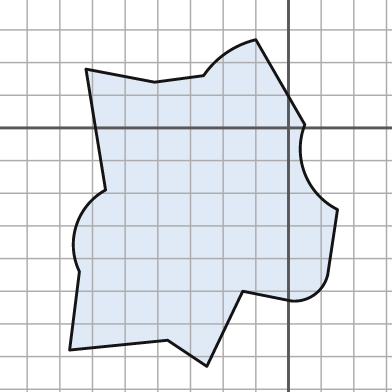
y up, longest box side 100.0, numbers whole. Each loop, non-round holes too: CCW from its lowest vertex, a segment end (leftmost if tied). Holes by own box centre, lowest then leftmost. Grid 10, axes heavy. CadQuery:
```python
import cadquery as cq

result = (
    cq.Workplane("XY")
    .moveTo(-25.0, -73.0)
    .lineTo(-14.0, -50.0)
    .lineTo(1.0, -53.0)
    .threePointArc((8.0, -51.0), (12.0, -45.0))
    .lineTo(15.0, -25.0)
    .threePointArc((5.0, -14.0), (5.0, 1.0))
    .lineTo(-10.0, 27.0)
    .threePointArc((-19.0, 23.0), (-26.0, 16.0))
    .lineTo(-41.0, 14.0)
    .lineTo(-62.0, 18.0)
    .lineTo(-56.0, -19.0)
    .threePointArc((-65.0, -30.0), (-64.0, -44.0))
    .lineTo(-67.0, -68.0)
    .lineTo(-37.0, -65.0)
    .close()
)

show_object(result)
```